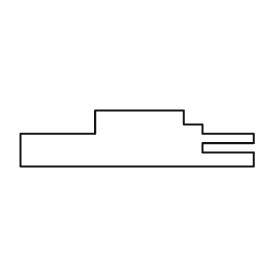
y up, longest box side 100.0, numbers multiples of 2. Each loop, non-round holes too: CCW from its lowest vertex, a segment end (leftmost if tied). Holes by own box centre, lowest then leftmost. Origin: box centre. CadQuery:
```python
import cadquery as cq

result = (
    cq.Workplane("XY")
    .moveTo(-50.0, -12.0)
    .lineTo(50.0, -12.0)
    .lineTo(50.0, -6.0)
    .lineTo(28.0, -6.0)
    .lineTo(28.0, -2.0)
    .lineTo(50.0, -2.0)
    .lineTo(50.0, 2.0)
    .lineTo(28.0, 2.0)
    .lineTo(28.0, 6.0)
    .lineTo(20.0, 6.0)
    .lineTo(20.0, 12.0)
    .lineTo(-18.0, 12.0)
    .lineTo(-18.0, 2.0)
    .lineTo(-50.0, 2.0)
    .close()
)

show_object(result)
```